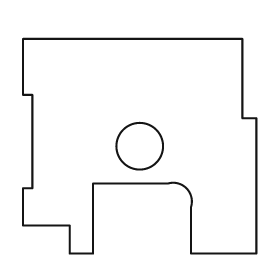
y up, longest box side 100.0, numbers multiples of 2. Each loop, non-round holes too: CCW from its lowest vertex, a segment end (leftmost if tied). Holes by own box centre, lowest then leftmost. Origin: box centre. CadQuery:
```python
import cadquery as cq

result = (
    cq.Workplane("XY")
    .moveTo(-30.0, -46.0)
    .lineTo(-20.0, -46.0)
    .lineTo(-20.0, -16.0)
    .lineTo(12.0, -16.0)
    .threePointArc((20.0, -18.0), (22.0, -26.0))
    .lineTo(22.0, -46.0)
    .lineTo(50.0, -46.0)
    .lineTo(50.0, 12.0)
    .lineTo(44.0, 12.0)
    .lineTo(44.0, 46.0)
    .lineTo(-50.0, 46.0)
    .lineTo(-50.0, 22.0)
    .lineTo(-46.0, 22.0)
    .lineTo(-46.0, -18.0)
    .lineTo(-50.0, -18.0)
    .lineTo(-50.0, -34.0)
    .lineTo(-30.0, -34.0)
    .close()
    .moveTo(0.0, 0.0)
    .circle(10.0)
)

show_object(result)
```